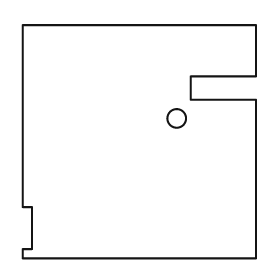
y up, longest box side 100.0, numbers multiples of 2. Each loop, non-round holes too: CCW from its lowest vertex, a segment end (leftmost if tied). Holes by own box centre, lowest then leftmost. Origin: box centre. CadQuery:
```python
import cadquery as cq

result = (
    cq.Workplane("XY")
    .moveTo(-50.0, -50.0)
    .lineTo(50.0, -50.0)
    .lineTo(50.0, 18.0)
    .lineTo(22.0, 18.0)
    .lineTo(22.0, 28.0)
    .lineTo(50.0, 28.0)
    .lineTo(50.0, 50.0)
    .lineTo(-50.0, 50.0)
    .lineTo(-50.0, -28.0)
    .lineTo(-46.0, -28.0)
    .lineTo(-46.0, -46.0)
    .lineTo(-50.0, -46.0)
    .close()
    .moveTo(16.0, 10.0)
    .circle(4.0)
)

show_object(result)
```